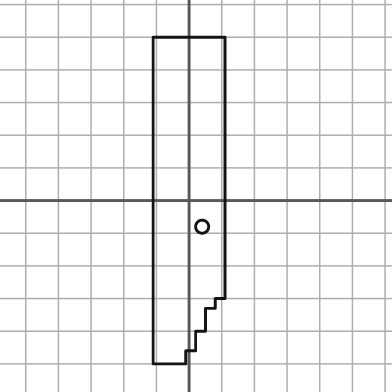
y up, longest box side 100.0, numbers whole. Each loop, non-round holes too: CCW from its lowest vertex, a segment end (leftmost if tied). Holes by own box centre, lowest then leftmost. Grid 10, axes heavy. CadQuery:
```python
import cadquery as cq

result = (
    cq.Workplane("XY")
    .moveTo(-11.0, -50.0)
    .lineTo(-1.0, -50.0)
    .lineTo(-1.0, -46.0)
    .lineTo(2.0, -46.0)
    .lineTo(2.0, -40.0)
    .lineTo(5.0, -40.0)
    .lineTo(5.0, -33.0)
    .lineTo(8.0, -33.0)
    .lineTo(8.0, -30.0)
    .lineTo(11.0, -30.0)
    .lineTo(11.0, 50.0)
    .lineTo(-11.0, 50.0)
    .close()
    .moveTo(4.0, -8.0)
    .circle(2.0)
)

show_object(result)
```